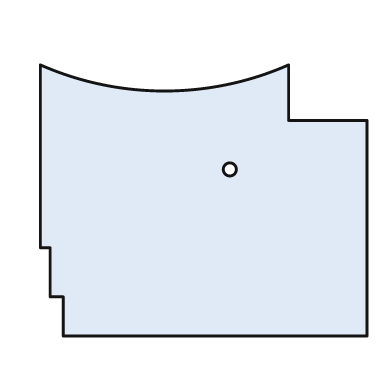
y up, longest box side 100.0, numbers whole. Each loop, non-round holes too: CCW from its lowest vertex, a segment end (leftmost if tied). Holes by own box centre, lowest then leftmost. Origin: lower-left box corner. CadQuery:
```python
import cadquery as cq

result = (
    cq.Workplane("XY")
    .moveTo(7.0, 0.0)
    .lineTo(100.0, 0.0)
    .lineTo(100.0, 66.0)
    .lineTo(76.0, 66.0)
    .lineTo(76.0, 83.0)
    .threePointArc((38.0, 75.0), (0.0, 83.0))
    .lineTo(0.0, 27.0)
    .lineTo(3.0, 27.0)
    .lineTo(3.0, 12.0)
    .lineTo(7.0, 12.0)
    .close()
    .moveTo(58.0, 51.0)
    .circle(2.0)
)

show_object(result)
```